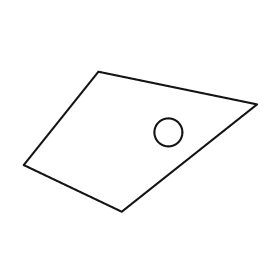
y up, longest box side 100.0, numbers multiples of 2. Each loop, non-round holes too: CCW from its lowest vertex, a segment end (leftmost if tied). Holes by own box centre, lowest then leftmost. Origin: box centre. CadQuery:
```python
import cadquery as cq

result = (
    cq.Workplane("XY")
    .moveTo(-8.0, -30.0)
    .lineTo(50.0, 16.0)
    .lineTo(-18.0, 30.0)
    .lineTo(-50.0, -10.0)
    .close()
    .moveTo(12.0, 4.0)
    .circle(6.0)
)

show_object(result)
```